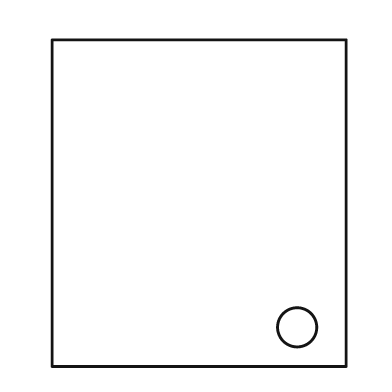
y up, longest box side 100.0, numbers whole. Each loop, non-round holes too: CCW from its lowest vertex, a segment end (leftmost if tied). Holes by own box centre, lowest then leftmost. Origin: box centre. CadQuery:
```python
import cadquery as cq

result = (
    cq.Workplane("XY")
    .moveTo(-45.0, -50.0)
    .lineTo(45.0, -50.0)
    .lineTo(45.0, 50.0)
    .lineTo(-45.0, 50.0)
    .close()
    .moveTo(30.0, -38.0)
    .circle(6.0)
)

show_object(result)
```